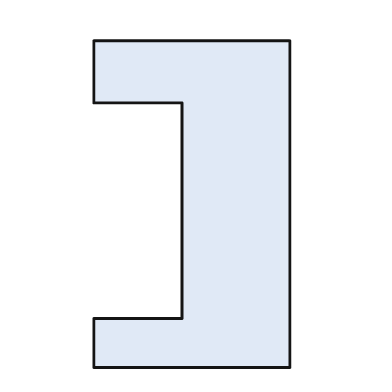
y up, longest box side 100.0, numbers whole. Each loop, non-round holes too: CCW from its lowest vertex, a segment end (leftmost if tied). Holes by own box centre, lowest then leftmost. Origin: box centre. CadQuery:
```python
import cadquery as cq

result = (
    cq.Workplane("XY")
    .moveTo(-30.0, -50.0)
    .lineTo(30.0, -50.0)
    .lineTo(30.0, 50.0)
    .lineTo(-30.0, 50.0)
    .lineTo(-30.0, 31.0)
    .lineTo(-3.0, 31.0)
    .lineTo(-3.0, -35.0)
    .lineTo(-30.0, -35.0)
    .close()
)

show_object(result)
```